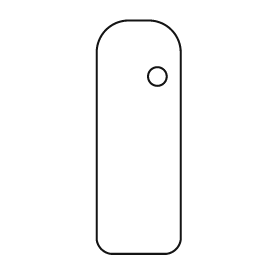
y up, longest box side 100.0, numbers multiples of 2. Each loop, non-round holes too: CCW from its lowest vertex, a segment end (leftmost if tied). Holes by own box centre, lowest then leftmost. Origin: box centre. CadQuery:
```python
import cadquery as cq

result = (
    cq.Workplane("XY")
    .moveTo(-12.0, -50.0)
    .lineTo(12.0, -50.0)
    .threePointArc((16.0, -48.0), (18.0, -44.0))
    .lineTo(18.0, 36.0)
    .threePointArc((14.0, 46.0), (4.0, 50.0))
    .lineTo(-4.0, 50.0)
    .threePointArc((-14.0, 46.0), (-18.0, 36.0))
    .lineTo(-18.0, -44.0)
    .threePointArc((-16.0, -48.0), (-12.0, -50.0))
    .close()
    .moveTo(8.0, 26.0)
    .circle(4.0)
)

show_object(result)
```